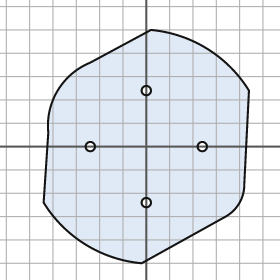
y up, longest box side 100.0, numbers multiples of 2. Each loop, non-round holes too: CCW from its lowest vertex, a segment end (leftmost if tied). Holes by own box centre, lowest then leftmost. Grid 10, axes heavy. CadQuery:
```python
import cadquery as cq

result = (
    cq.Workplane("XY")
    .moveTo(-2.0, -50.0)
    .lineTo(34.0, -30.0)
    .threePointArc((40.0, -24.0), (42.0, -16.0))
    .lineTo(44.0, 24.0)
    .threePointArc((26.0, 42.0), (2.0, 50.0))
    .lineTo(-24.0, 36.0)
    .threePointArc((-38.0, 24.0), (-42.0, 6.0))
    .lineTo(-44.0, -24.0)
    .threePointArc((-26.0, -42.0), (-2.0, -50.0))
    .close()
    .moveTo(0.0, -24.0)
    .circle(2.0)
    .moveTo(-24.0, 0.0)
    .circle(2.0)
    .moveTo(24.0, 0.0)
    .circle(2.0)
    .moveTo(0.0, 24.0)
    .circle(2.0)
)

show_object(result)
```